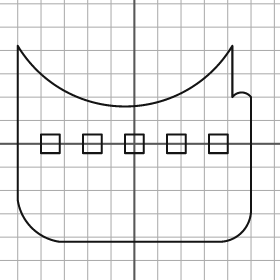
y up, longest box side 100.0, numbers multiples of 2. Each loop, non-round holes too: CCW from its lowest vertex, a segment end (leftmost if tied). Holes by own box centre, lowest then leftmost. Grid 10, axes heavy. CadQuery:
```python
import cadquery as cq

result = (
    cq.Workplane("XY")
    .moveTo(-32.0, -42.0)
    .lineTo(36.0, -42.0)
    .threePointArc((46.0, -38.0), (50.0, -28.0))
    .lineTo(50.0, 20.0)
    .threePointArc((46.0, 22.0), (42.0, 20.0))
    .lineTo(42.0, 42.0)
    .threePointArc((-4.0, 16.0), (-50.0, 42.0))
    .lineTo(-50.0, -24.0)
    .threePointArc((-44.0, -36.0), (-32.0, -42.0))
    .close()
    .moveTo(-40.0, -4.0)
    .lineTo(-32.0, -4.0)
    .lineTo(-32.0, 4.0)
    .lineTo(-40.0, 4.0)
    .close()
    .moveTo(-22.0, -4.0)
    .lineTo(-14.0, -4.0)
    .lineTo(-14.0, 4.0)
    .lineTo(-22.0, 4.0)
    .close()
    .moveTo(-4.0, -4.0)
    .lineTo(4.0, -4.0)
    .lineTo(4.0, 4.0)
    .lineTo(-4.0, 4.0)
    .close()
    .moveTo(14.0, -4.0)
    .lineTo(22.0, -4.0)
    .lineTo(22.0, 4.0)
    .lineTo(14.0, 4.0)
    .close()
    .moveTo(32.0, -4.0)
    .lineTo(40.0, -4.0)
    .lineTo(40.0, 4.0)
    .lineTo(32.0, 4.0)
    .close()
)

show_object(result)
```